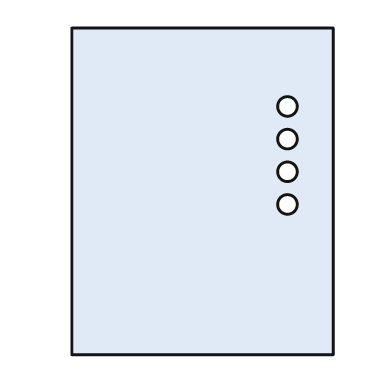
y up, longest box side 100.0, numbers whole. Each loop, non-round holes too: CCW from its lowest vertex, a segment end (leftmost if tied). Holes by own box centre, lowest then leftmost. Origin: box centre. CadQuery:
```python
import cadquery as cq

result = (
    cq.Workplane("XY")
    .moveTo(-40.0, -50.0)
    .lineTo(40.0, -50.0)
    .lineTo(40.0, 50.0)
    .lineTo(-40.0, 50.0)
    .close()
    .moveTo(26.0, -4.0)
    .circle(3.0)
    .moveTo(26.0, 6.0)
    .circle(3.0)
    .moveTo(26.0, 16.0)
    .circle(3.0)
    .moveTo(26.0, 26.0)
    .circle(3.0)
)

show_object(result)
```